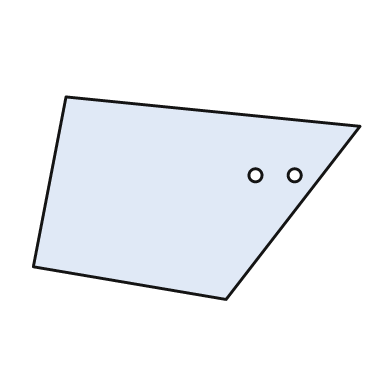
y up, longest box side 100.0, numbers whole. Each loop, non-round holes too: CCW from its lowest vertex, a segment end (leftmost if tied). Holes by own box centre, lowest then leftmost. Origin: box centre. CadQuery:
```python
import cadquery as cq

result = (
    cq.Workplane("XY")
    .moveTo(9.0, -31.0)
    .lineTo(50.0, 22.0)
    .lineTo(-40.0, 31.0)
    .lineTo(-50.0, -21.0)
    .close()
    .moveTo(18.0, 7.0)
    .circle(2.0)
    .moveTo(30.0, 7.0)
    .circle(2.0)
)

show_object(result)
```